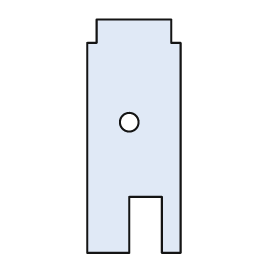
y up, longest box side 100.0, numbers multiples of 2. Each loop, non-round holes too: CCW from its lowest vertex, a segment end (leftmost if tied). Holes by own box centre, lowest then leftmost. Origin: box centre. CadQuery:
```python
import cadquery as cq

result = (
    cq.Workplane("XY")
    .moveTo(-20.0, -50.0)
    .lineTo(-2.0, -50.0)
    .lineTo(-2.0, -26.0)
    .lineTo(12.0, -26.0)
    .lineTo(12.0, -50.0)
    .lineTo(20.0, -50.0)
    .lineTo(20.0, 40.0)
    .lineTo(16.0, 40.0)
    .lineTo(16.0, 50.0)
    .lineTo(-16.0, 50.0)
    .lineTo(-16.0, 40.0)
    .lineTo(-20.0, 40.0)
    .close()
    .moveTo(-2.0, 6.0)
    .circle(4.0)
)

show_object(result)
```